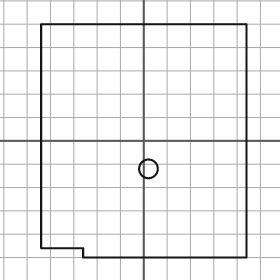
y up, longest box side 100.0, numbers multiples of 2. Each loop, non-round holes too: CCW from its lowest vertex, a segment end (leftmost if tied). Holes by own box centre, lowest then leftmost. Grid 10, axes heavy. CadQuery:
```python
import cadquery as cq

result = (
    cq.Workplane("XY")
    .moveTo(-26.0, -50.0)
    .lineTo(44.0, -50.0)
    .lineTo(44.0, 50.0)
    .lineTo(-44.0, 50.0)
    .lineTo(-44.0, -46.0)
    .lineTo(-26.0, -46.0)
    .close()
    .moveTo(2.0, -12.0)
    .circle(4.0)
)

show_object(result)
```